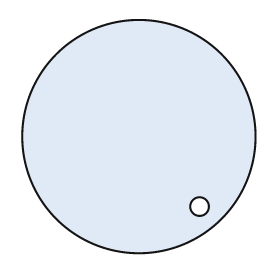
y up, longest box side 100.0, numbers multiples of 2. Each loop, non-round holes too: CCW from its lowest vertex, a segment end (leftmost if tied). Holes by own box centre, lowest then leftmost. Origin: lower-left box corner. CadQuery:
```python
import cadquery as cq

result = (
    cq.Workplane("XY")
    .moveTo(50.0, 50.0)
    .circle(50.0)
    .moveTo(76.0, 20.0)
    .circle(4.0)
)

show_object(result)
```